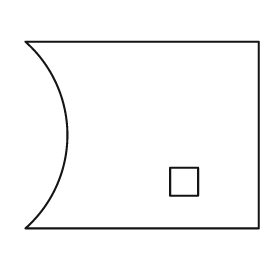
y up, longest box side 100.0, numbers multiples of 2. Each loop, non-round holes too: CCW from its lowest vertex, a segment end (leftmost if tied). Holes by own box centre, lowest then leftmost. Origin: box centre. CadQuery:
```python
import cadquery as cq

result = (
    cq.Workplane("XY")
    .moveTo(-50.0, -40.0)
    .lineTo(50.0, -40.0)
    .lineTo(50.0, 40.0)
    .lineTo(-50.0, 40.0)
    .threePointArc((-32.0, 0.0), (-50.0, -40.0))
    .close()
    .moveTo(12.0, -26.0)
    .lineTo(24.0, -26.0)
    .lineTo(24.0, -14.0)
    .lineTo(12.0, -14.0)
    .close()
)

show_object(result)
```